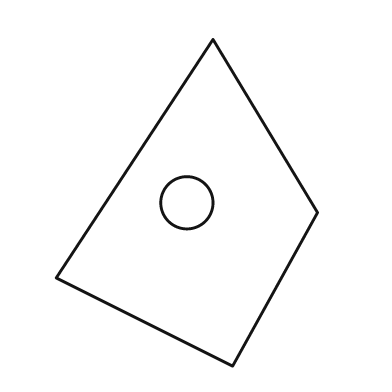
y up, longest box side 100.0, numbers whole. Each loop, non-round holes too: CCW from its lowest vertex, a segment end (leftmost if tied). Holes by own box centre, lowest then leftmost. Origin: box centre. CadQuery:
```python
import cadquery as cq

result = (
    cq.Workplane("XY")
    .moveTo(14.0, -50.0)
    .lineTo(40.0, -3.0)
    .lineTo(8.0, 50.0)
    .lineTo(-40.0, -23.0)
    .close()
    .moveTo(0.0, 0.0)
    .circle(8.0)
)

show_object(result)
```